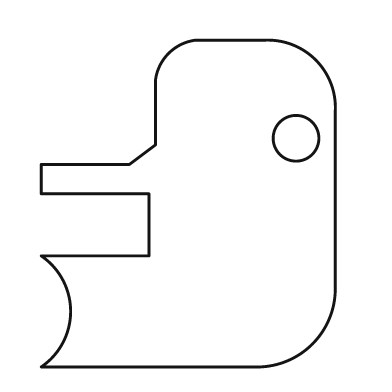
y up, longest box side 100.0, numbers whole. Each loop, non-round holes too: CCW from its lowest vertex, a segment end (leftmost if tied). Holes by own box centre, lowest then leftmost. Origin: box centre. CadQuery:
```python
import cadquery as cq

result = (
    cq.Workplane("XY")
    .moveTo(-45.0, -50.0)
    .lineTo(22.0, -50.0)
    .threePointArc((38.0, -43.0), (45.0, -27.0))
    .lineTo(45.0, 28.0)
    .threePointArc((39.0, 44.0), (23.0, 50.0))
    .lineTo(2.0, 50.0)
    .threePointArc((-6.0, 46.0), (-10.0, 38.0))
    .lineTo(-10.0, 18.0)
    .lineTo(-18.0, 12.0)
    .lineTo(-45.0, 12.0)
    .lineTo(-45.0, 3.0)
    .lineTo(-12.0, 3.0)
    .lineTo(-12.0, -16.0)
    .lineTo(-45.0, -16.0)
    .threePointArc((-36.0, -33.0), (-45.0, -50.0))
    .close()
    .moveTo(33.0, 20.0)
    .circle(7.0)
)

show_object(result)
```